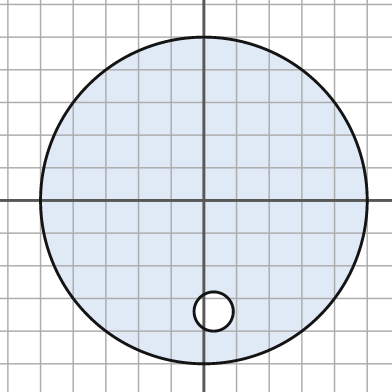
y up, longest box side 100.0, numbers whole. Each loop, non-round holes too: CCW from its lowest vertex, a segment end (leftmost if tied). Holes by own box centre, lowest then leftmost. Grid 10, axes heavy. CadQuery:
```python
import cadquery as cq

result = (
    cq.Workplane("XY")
    .moveTo(0.0, 0.0)
    .circle(50.0)
    .moveTo(3.0, -34.0)
    .circle(6.0)
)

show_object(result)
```